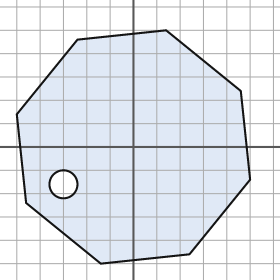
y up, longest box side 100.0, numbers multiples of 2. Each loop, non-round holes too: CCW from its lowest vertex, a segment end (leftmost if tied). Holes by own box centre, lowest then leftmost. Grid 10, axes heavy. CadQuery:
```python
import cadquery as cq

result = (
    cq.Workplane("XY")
    .moveTo(-14.0, -50.0)
    .lineTo(24.0, -46.0)
    .lineTo(50.0, -14.0)
    .lineTo(46.0, 24.0)
    .lineTo(14.0, 50.0)
    .lineTo(-24.0, 46.0)
    .lineTo(-50.0, 14.0)
    .lineTo(-46.0, -24.0)
    .close()
    .moveTo(-30.0, -16.0)
    .circle(6.0)
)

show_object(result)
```